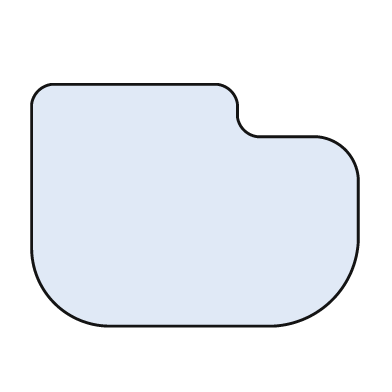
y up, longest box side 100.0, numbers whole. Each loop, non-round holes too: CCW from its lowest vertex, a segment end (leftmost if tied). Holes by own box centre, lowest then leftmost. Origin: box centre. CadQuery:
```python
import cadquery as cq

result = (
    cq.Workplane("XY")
    .moveTo(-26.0, -37.0)
    .lineTo(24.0, -37.0)
    .threePointArc((42.0, -29.0), (50.0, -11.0))
    .lineTo(50.0, 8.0)
    .threePointArc((46.0, 17.0), (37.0, 21.0))
    .lineTo(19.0, 21.0)
    .threePointArc((15.0, 23.0), (13.0, 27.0))
    .lineTo(13.0, 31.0)
    .threePointArc((11.0, 35.0), (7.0, 37.0))
    .lineTo(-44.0, 37.0)
    .threePointArc((-48.0, 35.0), (-50.0, 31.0))
    .lineTo(-50.0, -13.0)
    .threePointArc((-43.0, -30.0), (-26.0, -37.0))
    .close()
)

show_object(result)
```